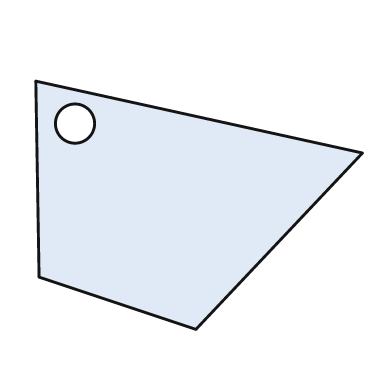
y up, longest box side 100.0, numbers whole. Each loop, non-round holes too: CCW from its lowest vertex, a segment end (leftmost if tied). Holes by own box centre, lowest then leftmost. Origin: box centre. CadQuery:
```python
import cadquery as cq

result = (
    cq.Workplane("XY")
    .moveTo(-1.0, -38.0)
    .lineTo(50.0, 16.0)
    .lineTo(-50.0, 38.0)
    .lineTo(-49.0, -22.0)
    .close()
    .moveTo(-38.0, 25.0)
    .circle(6.0)
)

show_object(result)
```